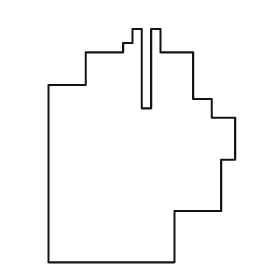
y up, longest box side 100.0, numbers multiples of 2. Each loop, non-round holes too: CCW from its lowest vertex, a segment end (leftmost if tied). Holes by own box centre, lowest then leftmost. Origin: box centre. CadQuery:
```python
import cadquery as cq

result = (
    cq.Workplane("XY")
    .moveTo(-40.0, -50.0)
    .lineTo(14.0, -50.0)
    .lineTo(14.0, -28.0)
    .lineTo(34.0, -28.0)
    .lineTo(34.0, -6.0)
    .lineTo(40.0, -6.0)
    .lineTo(40.0, 12.0)
    .lineTo(30.0, 12.0)
    .lineTo(30.0, 20.0)
    .lineTo(22.0, 20.0)
    .lineTo(22.0, 40.0)
    .lineTo(8.0, 40.0)
    .lineTo(8.0, 50.0)
    .lineTo(4.0, 50.0)
    .lineTo(4.0, 16.0)
    .lineTo(0.0, 16.0)
    .lineTo(0.0, 50.0)
    .lineTo(-4.0, 50.0)
    .lineTo(-4.0, 44.0)
    .lineTo(-8.0, 44.0)
    .lineTo(-8.0, 40.0)
    .lineTo(-24.0, 40.0)
    .lineTo(-24.0, 26.0)
    .lineTo(-40.0, 26.0)
    .close()
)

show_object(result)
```